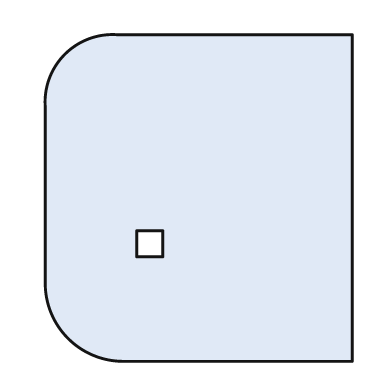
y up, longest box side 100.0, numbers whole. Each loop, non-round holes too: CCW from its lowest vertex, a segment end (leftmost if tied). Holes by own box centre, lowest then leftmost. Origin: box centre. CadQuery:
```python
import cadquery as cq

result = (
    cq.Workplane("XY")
    .moveTo(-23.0, -50.0)
    .lineTo(47.0, -50.0)
    .lineTo(47.0, 50.0)
    .lineTo(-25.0, 50.0)
    .threePointArc((-41.0, 44.0), (-47.0, 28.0))
    .lineTo(-47.0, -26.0)
    .threePointArc((-40.0, -43.0), (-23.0, -50.0))
    .close()
    .moveTo(-19.0, -18.0)
    .lineTo(-11.0, -18.0)
    .lineTo(-11.0, -10.0)
    .lineTo(-19.0, -10.0)
    .close()
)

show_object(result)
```